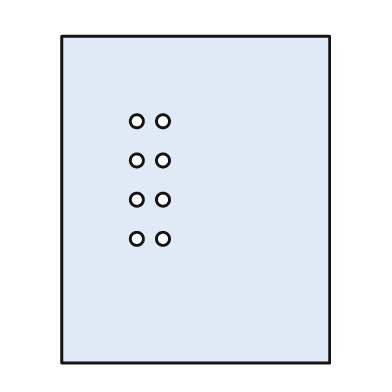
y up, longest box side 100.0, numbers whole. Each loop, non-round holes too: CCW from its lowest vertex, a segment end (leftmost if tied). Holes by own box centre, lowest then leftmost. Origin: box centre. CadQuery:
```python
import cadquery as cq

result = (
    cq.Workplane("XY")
    .moveTo(-41.0, -50.0)
    .lineTo(41.0, -50.0)
    .lineTo(41.0, 50.0)
    .lineTo(-41.0, 50.0)
    .close()
    .moveTo(-18.0, -12.0)
    .circle(2.0)
    .moveTo(-10.0, -12.0)
    .circle(2.0)
    .moveTo(-18.0, 0.0)
    .circle(2.0)
    .moveTo(-10.0, 0.0)
    .circle(2.0)
    .moveTo(-18.0, 12.0)
    .circle(2.0)
    .moveTo(-10.0, 12.0)
    .circle(2.0)
    .moveTo(-18.0, 24.0)
    .circle(2.0)
    .moveTo(-10.0, 24.0)
    .circle(2.0)
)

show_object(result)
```